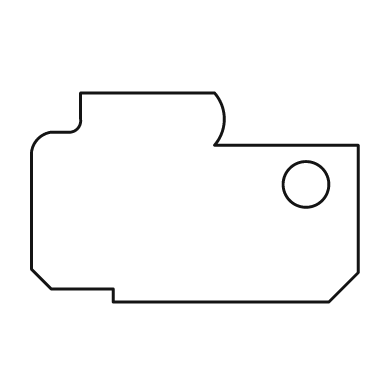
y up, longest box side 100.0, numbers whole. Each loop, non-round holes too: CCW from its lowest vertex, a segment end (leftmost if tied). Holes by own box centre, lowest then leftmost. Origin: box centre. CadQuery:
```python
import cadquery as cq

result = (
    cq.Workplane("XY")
    .moveTo(-25.0, -32.0)
    .lineTo(41.0, -32.0)
    .lineTo(50.0, -23.0)
    .lineTo(50.0, 16.0)
    .lineTo(6.0, 16.0)
    .threePointArc((9.0, 24.0), (6.0, 32.0))
    .lineTo(-35.0, 32.0)
    .lineTo(-35.0, 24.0)
    .threePointArc((-36.0, 21.0), (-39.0, 20.0))
    .lineTo(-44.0, 20.0)
    .threePointArc((-48.0, 18.0), (-50.0, 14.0))
    .lineTo(-50.0, -22.0)
    .lineTo(-44.0, -28.0)
    .lineTo(-25.0, -28.0)
    .close()
    .moveTo(34.0, 4.0)
    .circle(7.0)
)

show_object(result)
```